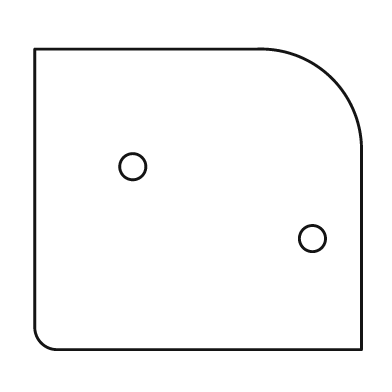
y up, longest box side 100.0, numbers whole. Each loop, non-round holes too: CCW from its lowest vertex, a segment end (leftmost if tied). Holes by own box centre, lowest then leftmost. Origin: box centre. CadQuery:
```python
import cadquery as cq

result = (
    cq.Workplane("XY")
    .moveTo(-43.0, -46.0)
    .lineTo(50.0, -46.0)
    .lineTo(50.0, 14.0)
    .threePointArc((41.0, 37.0), (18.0, 46.0))
    .lineTo(-50.0, 46.0)
    .lineTo(-50.0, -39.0)
    .threePointArc((-48.0, -44.0), (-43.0, -46.0))
    .close()
    .moveTo(35.0, -12.0)
    .circle(4.0)
    .moveTo(-20.0, 10.0)
    .circle(4.0)
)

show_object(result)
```